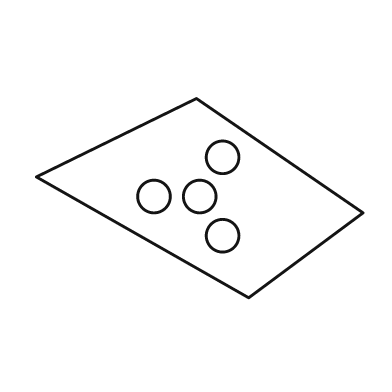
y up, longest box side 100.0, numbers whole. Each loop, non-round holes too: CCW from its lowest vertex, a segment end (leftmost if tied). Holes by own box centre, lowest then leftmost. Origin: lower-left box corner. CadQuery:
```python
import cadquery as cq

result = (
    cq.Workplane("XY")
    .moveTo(65.0, 0.0)
    .lineTo(100.0, 26.0)
    .lineTo(49.0, 61.0)
    .lineTo(0.0, 37.0)
    .close()
    .moveTo(57.0, 19.0)
    .circle(5.0)
    .moveTo(36.0, 31.0)
    .circle(5.0)
    .moveTo(50.0, 31.0)
    .circle(5.0)
    .moveTo(57.0, 43.0)
    .circle(5.0)
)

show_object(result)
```